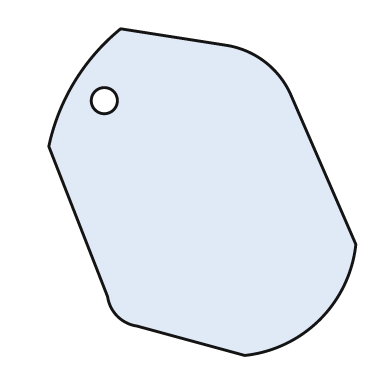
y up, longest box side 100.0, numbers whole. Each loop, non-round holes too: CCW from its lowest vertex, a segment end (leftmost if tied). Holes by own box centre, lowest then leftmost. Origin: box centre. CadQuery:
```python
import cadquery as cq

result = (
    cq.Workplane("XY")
    .moveTo(13.0, -50.0)
    .threePointArc((36.0, -39.0), (47.0, -16.0))
    .lineTo(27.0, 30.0)
    .threePointArc((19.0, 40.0), (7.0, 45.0))
    .lineTo(-25.0, 50.0)
    .threePointArc((-39.0, 34.0), (-47.0, 14.0))
    .lineTo(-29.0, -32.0)
    .threePointArc((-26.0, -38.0), (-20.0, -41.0))
    .close()
    .moveTo(-30.0, 28.0)
    .circle(4.0)
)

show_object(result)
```